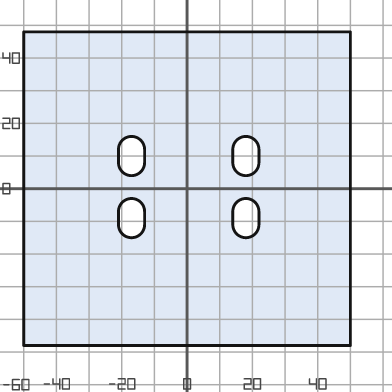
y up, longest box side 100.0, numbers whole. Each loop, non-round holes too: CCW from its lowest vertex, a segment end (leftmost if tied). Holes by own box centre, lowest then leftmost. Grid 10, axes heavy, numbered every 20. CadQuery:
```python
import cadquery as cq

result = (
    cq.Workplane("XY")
    .moveTo(-50.0, -48.0)
    .lineTo(50.0, -48.0)
    .lineTo(50.0, 48.0)
    .lineTo(-50.0, 48.0)
    .close()
    .moveTo(-21.0, -11.0)
    .threePointArc((-17.0, -15.0), (-13.0, -11.0))
    .lineTo(-13.0, -7.0)
    .threePointArc((-17.0, -3.0), (-21.0, -7.0))
    .close()
    .moveTo(14.0, -11.0)
    .threePointArc((18.0, -15.0), (22.0, -11.0))
    .lineTo(22.0, -7.0)
    .threePointArc((18.0, -3.0), (14.0, -7.0))
    .close()
    .moveTo(-21.0, 8.0)
    .threePointArc((-17.0, 4.0), (-13.0, 8.0))
    .lineTo(-13.0, 12.0)
    .threePointArc((-17.0, 16.0), (-21.0, 12.0))
    .close()
    .moveTo(14.0, 8.0)
    .threePointArc((18.0, 4.0), (22.0, 8.0))
    .lineTo(22.0, 12.0)
    .threePointArc((18.0, 16.0), (14.0, 12.0))
    .close()
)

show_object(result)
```